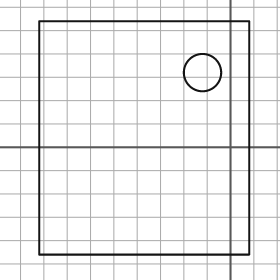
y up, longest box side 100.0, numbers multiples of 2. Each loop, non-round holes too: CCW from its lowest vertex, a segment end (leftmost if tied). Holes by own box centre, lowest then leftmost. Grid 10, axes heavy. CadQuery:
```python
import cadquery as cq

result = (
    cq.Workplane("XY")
    .moveTo(-82.0, -46.0)
    .lineTo(8.0, -46.0)
    .lineTo(8.0, 54.0)
    .lineTo(-82.0, 54.0)
    .close()
    .moveTo(-12.0, 32.0)
    .circle(8.0)
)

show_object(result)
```